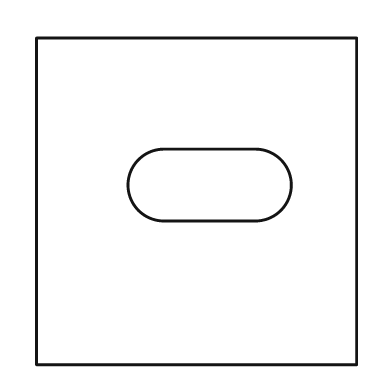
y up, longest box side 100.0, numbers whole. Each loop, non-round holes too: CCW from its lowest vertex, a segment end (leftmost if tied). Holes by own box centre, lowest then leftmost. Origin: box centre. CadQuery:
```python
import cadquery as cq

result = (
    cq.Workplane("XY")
    .moveTo(-49.0, -50.0)
    .lineTo(49.0, -50.0)
    .lineTo(49.0, 50.0)
    .lineTo(-49.0, 50.0)
    .close()
    .moveTo(-10.0, -6.0)
    .lineTo(18.0, -6.0)
    .threePointArc((29.0, 5.0), (18.0, 16.0))
    .lineTo(-10.0, 16.0)
    .threePointArc((-21.0, 5.0), (-10.0, -6.0))
    .close()
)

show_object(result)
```